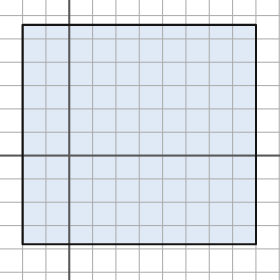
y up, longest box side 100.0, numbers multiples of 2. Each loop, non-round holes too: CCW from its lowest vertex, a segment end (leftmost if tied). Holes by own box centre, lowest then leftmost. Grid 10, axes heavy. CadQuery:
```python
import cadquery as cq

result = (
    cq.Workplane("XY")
    .moveTo(-20.0, -38.0)
    .lineTo(80.0, -38.0)
    .lineTo(80.0, 56.0)
    .lineTo(-20.0, 56.0)
    .close()
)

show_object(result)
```